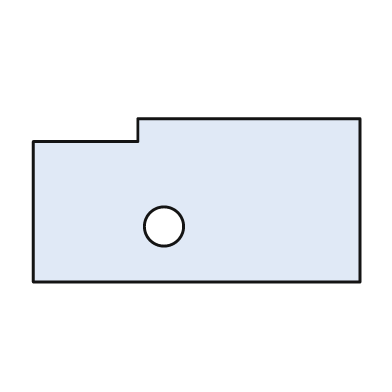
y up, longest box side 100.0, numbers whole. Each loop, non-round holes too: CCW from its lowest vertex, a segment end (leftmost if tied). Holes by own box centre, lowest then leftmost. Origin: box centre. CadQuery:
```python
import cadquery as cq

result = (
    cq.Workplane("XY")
    .moveTo(-50.0, -25.0)
    .lineTo(50.0, -25.0)
    .lineTo(50.0, 25.0)
    .lineTo(-18.0, 25.0)
    .lineTo(-18.0, 18.0)
    .lineTo(-50.0, 18.0)
    .close()
    .moveTo(-10.0, -8.0)
    .circle(6.0)
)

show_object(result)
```